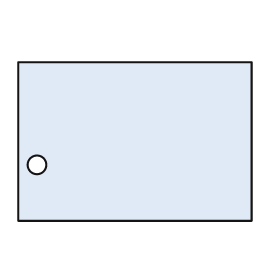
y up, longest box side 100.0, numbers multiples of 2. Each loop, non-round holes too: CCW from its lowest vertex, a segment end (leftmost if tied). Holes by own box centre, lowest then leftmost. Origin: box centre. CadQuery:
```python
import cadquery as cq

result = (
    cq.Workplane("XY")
    .moveTo(-50.0, -34.0)
    .lineTo(50.0, -34.0)
    .lineTo(50.0, 34.0)
    .lineTo(-50.0, 34.0)
    .close()
    .moveTo(-42.0, -10.0)
    .circle(4.0)
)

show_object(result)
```